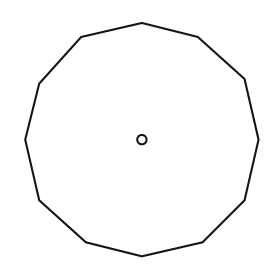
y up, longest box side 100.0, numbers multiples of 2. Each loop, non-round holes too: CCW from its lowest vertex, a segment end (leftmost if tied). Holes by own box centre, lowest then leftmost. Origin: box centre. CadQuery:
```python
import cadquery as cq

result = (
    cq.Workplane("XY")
    .moveTo(0.0, -50.0)
    .lineTo(26.0, -44.0)
    .lineTo(44.0, -26.0)
    .lineTo(50.0, 0.0)
    .lineTo(44.0, 26.0)
    .lineTo(24.0, 44.0)
    .lineTo(0.0, 50.0)
    .lineTo(-26.0, 44.0)
    .lineTo(-44.0, 24.0)
    .lineTo(-50.0, 0.0)
    .lineTo(-44.0, -26.0)
    .lineTo(-24.0, -44.0)
    .close()
    .moveTo(0.0, 0.0)
    .circle(2.0)
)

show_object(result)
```